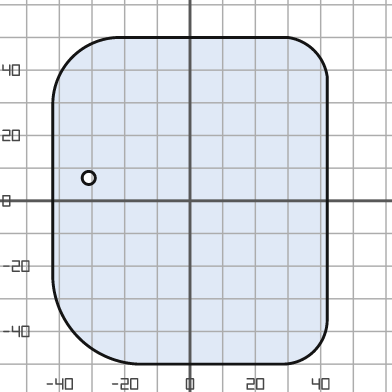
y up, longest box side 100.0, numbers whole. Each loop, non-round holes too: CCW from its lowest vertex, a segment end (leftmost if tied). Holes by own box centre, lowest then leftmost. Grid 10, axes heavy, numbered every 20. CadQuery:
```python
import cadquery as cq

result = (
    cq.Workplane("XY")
    .moveTo(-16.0, -50.0)
    .lineTo(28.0, -50.0)
    .threePointArc((38.0, -46.0), (42.0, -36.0))
    .lineTo(42.0, 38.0)
    .threePointArc((38.0, 46.0), (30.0, 50.0))
    .lineTo(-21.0, 50.0)
    .threePointArc((-36.0, 44.0), (-42.0, 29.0))
    .lineTo(-42.0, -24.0)
    .threePointArc((-34.0, -42.0), (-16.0, -50.0))
    .close()
    .moveTo(-31.0, 7.0)
    .circle(2.0)
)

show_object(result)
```